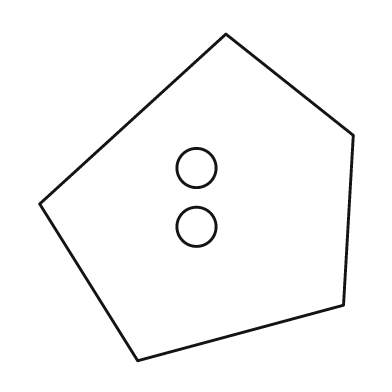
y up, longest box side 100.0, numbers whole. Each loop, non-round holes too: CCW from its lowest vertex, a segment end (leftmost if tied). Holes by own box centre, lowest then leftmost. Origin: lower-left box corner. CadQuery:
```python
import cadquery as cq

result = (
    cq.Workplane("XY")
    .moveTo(30.0, 0.0)
    .lineTo(93.0, 17.0)
    .lineTo(96.0, 69.0)
    .lineTo(57.0, 100.0)
    .lineTo(0.0, 48.0)
    .close()
    .moveTo(48.0, 41.0)
    .circle(6.0)
    .moveTo(48.0, 59.0)
    .circle(6.0)
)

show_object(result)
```